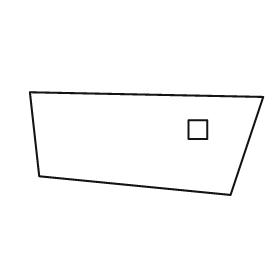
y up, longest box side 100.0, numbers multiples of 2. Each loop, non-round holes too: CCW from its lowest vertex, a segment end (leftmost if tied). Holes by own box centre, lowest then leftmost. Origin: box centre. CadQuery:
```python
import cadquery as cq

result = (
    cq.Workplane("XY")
    .moveTo(36.0, -22.0)
    .lineTo(50.0, 20.0)
    .lineTo(-50.0, 22.0)
    .lineTo(-46.0, -14.0)
    .close()
    .moveTo(18.0, 2.0)
    .lineTo(26.0, 2.0)
    .lineTo(26.0, 10.0)
    .lineTo(18.0, 10.0)
    .close()
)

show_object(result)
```